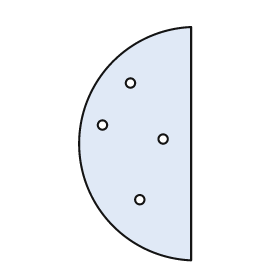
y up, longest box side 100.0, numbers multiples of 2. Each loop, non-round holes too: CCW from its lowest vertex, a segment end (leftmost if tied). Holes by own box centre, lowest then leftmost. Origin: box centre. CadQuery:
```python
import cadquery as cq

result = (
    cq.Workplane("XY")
    .moveTo(24.0, -50.0)
    .lineTo(24.0, 50.0)
    .threePointArc((-24.0, 0.0), (24.0, -50.0))
    .close()
    .moveTo(2.0, -24.0)
    .circle(2.0)
    .moveTo(12.0, 2.0)
    .circle(2.0)
    .moveTo(-14.0, 8.0)
    .circle(2.0)
    .moveTo(-2.0, 26.0)
    .circle(2.0)
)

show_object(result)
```